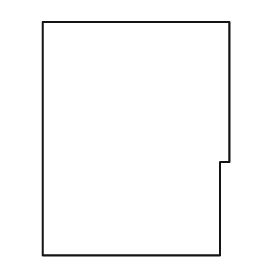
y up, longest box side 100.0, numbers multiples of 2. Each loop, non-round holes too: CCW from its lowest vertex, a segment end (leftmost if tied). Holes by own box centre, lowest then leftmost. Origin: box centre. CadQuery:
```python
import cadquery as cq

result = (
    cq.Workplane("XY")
    .moveTo(-40.0, -50.0)
    .lineTo(36.0, -50.0)
    .lineTo(36.0, -10.0)
    .lineTo(40.0, -10.0)
    .lineTo(40.0, 50.0)
    .lineTo(-40.0, 50.0)
    .close()
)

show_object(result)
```